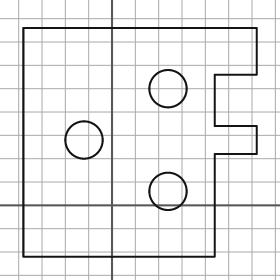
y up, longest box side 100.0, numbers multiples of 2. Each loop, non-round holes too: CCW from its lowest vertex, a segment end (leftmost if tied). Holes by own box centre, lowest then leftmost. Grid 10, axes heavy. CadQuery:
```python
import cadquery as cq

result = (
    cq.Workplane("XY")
    .moveTo(-38.0, -22.0)
    .lineTo(44.0, -22.0)
    .lineTo(44.0, 22.0)
    .lineTo(62.0, 22.0)
    .lineTo(62.0, 34.0)
    .lineTo(44.0, 34.0)
    .lineTo(44.0, 56.0)
    .lineTo(62.0, 56.0)
    .lineTo(62.0, 76.0)
    .lineTo(-38.0, 76.0)
    .close()
    .moveTo(24.0, 6.0)
    .circle(8.0)
    .moveTo(-12.0, 28.0)
    .circle(8.0)
    .moveTo(24.0, 50.0)
    .circle(8.0)
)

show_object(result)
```